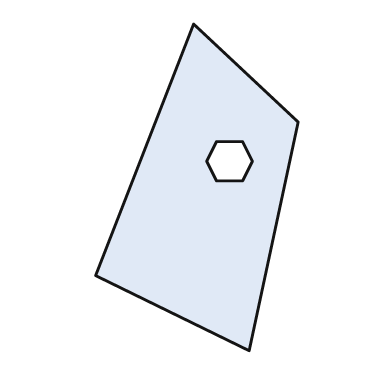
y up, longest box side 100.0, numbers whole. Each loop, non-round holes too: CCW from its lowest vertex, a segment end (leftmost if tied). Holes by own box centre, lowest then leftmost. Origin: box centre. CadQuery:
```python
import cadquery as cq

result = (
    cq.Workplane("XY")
    .moveTo(16.0, -50.0)
    .lineTo(31.0, 20.0)
    .lineTo(-1.0, 50.0)
    .lineTo(-31.0, -27.0)
    .close()
    .moveTo(6.0, 2.0)
    .lineTo(14.0, 2.0)
    .lineTo(17.0, 8.0)
    .lineTo(14.0, 14.0)
    .lineTo(6.0, 14.0)
    .lineTo(3.0, 8.0)
    .close()
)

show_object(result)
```